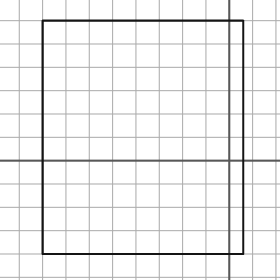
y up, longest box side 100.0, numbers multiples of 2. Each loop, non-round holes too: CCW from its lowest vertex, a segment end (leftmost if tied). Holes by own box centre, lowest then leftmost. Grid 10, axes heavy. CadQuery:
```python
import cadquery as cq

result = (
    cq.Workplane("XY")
    .moveTo(-80.0, -40.0)
    .lineTo(6.0, -40.0)
    .lineTo(6.0, 60.0)
    .lineTo(-80.0, 60.0)
    .close()
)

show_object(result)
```